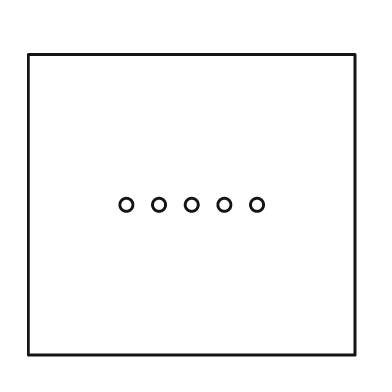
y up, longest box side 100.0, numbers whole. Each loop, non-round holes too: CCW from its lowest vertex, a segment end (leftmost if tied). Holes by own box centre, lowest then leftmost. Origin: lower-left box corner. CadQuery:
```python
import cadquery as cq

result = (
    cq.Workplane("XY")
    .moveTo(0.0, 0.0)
    .lineTo(100.0, 0.0)
    .lineTo(100.0, 92.0)
    .lineTo(0.0, 92.0)
    .close()
    .moveTo(30.0, 46.0)
    .circle(2.0)
    .moveTo(40.0, 46.0)
    .circle(2.0)
    .moveTo(50.0, 46.0)
    .circle(2.0)
    .moveTo(60.0, 46.0)
    .circle(2.0)
    .moveTo(70.0, 46.0)
    .circle(2.0)
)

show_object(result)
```